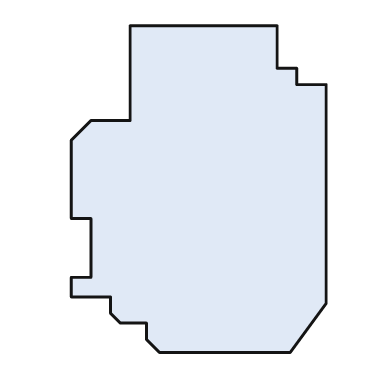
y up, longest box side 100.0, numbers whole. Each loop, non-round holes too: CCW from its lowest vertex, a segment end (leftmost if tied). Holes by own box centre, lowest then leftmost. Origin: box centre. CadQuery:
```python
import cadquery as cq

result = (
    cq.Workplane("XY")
    .moveTo(-12.0, -50.0)
    .lineTo(28.0, -50.0)
    .lineTo(39.0, -35.0)
    .lineTo(39.0, 32.0)
    .lineTo(30.0, 32.0)
    .lineTo(30.0, 37.0)
    .lineTo(24.0, 37.0)
    .lineTo(24.0, 50.0)
    .lineTo(-21.0, 50.0)
    .lineTo(-21.0, 21.0)
    .lineTo(-33.0, 21.0)
    .lineTo(-39.0, 15.0)
    .lineTo(-39.0, -9.0)
    .lineTo(-33.0, -9.0)
    .lineTo(-33.0, -27.0)
    .lineTo(-39.0, -27.0)
    .lineTo(-39.0, -33.0)
    .lineTo(-27.0, -33.0)
    .lineTo(-27.0, -38.0)
    .lineTo(-24.0, -41.0)
    .lineTo(-16.0, -41.0)
    .lineTo(-16.0, -46.0)
    .close()
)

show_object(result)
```